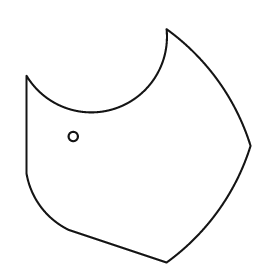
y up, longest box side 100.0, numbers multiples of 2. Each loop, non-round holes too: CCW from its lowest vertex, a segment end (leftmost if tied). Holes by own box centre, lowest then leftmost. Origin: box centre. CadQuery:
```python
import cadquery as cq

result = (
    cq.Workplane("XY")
    .moveTo(12.0, -50.0)
    .threePointArc((34.0, -28.0), (48.0, 0.0))
    .threePointArc((34.0, 28.0), (12.0, 50.0))
    .threePointArc((-10.0, 16.0), (-48.0, 30.0))
    .lineTo(-48.0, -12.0)
    .threePointArc((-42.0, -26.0), (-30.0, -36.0))
    .close()
    .moveTo(-28.0, 4.0)
    .circle(2.0)
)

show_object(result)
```